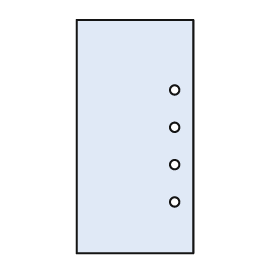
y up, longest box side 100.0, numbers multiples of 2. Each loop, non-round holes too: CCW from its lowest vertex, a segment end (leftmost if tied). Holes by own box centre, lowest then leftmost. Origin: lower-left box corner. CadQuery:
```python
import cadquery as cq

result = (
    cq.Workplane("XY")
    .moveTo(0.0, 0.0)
    .lineTo(50.0, 0.0)
    .lineTo(50.0, 100.0)
    .lineTo(0.0, 100.0)
    .close()
    .moveTo(42.0, 22.0)
    .circle(2.0)
    .moveTo(42.0, 38.0)
    .circle(2.0)
    .moveTo(42.0, 54.0)
    .circle(2.0)
    .moveTo(42.0, 70.0)
    .circle(2.0)
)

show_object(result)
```